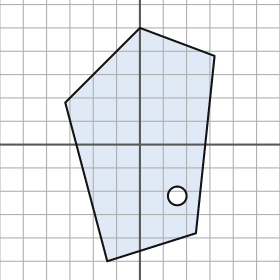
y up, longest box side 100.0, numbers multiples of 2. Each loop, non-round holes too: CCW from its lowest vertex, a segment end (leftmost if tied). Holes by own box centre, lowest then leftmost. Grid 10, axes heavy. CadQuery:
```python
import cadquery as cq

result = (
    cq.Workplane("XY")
    .moveTo(-14.0, -50.0)
    .lineTo(24.0, -38.0)
    .lineTo(32.0, 38.0)
    .lineTo(0.0, 50.0)
    .lineTo(-32.0, 18.0)
    .close()
    .moveTo(16.0, -22.0)
    .circle(4.0)
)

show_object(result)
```